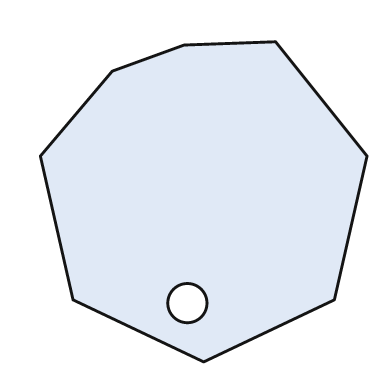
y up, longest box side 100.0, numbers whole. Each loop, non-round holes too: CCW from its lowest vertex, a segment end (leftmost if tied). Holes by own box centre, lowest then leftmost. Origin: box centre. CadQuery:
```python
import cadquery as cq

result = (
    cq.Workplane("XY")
    .moveTo(0.0, -49.0)
    .lineTo(40.0, -30.0)
    .lineTo(50.0, 14.0)
    .lineTo(22.0, 49.0)
    .lineTo(-6.0, 48.0)
    .lineTo(-28.0, 40.0)
    .lineTo(-50.0, 14.0)
    .lineTo(-40.0, -30.0)
    .close()
    .moveTo(-5.0, -31.0)
    .circle(6.0)
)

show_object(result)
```